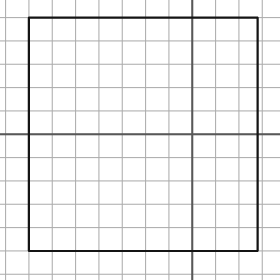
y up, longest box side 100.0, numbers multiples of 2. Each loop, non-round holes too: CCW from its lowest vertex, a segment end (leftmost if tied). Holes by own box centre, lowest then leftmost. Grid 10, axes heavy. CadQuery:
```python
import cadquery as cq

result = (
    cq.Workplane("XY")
    .moveTo(-70.0, -50.0)
    .lineTo(28.0, -50.0)
    .lineTo(28.0, 50.0)
    .lineTo(-70.0, 50.0)
    .close()
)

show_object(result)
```